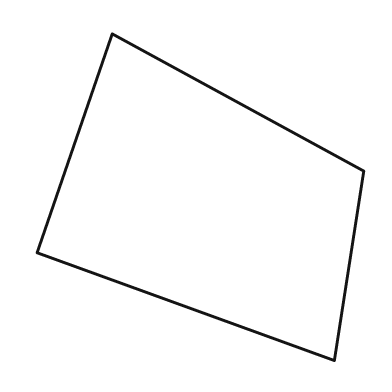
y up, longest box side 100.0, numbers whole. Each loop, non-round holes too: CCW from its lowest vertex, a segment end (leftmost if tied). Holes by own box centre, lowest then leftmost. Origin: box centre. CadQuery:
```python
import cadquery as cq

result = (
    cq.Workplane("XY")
    .moveTo(41.0, -50.0)
    .lineTo(50.0, 8.0)
    .lineTo(-27.0, 50.0)
    .lineTo(-50.0, -17.0)
    .close()
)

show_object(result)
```